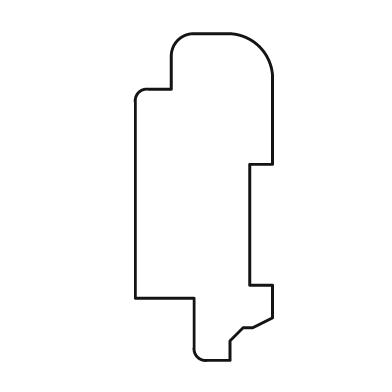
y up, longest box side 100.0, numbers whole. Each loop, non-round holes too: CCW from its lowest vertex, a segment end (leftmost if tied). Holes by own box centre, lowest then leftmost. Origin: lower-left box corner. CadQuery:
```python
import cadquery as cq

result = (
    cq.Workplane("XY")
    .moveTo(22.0, 0.0)
    .lineTo(29.0, 0.0)
    .lineTo(29.0, 6.0)
    .lineTo(33.0, 10.0)
    .lineTo(36.0, 10.0)
    .lineTo(42.0, 13.0)
    .lineTo(42.0, 23.0)
    .lineTo(35.0, 23.0)
    .lineTo(35.0, 60.0)
    .lineTo(42.0, 60.0)
    .lineTo(42.0, 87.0)
    .threePointArc((38.0, 96.0), (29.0, 100.0))
    .lineTo(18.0, 100.0)
    .threePointArc((13.0, 98.0), (11.0, 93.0))
    .lineTo(11.0, 83.0)
    .lineTo(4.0, 83.0)
    .threePointArc((1.0, 82.0), (0.0, 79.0))
    .lineTo(0.0, 19.0)
    .lineTo(18.0, 19.0)
    .lineTo(18.0, 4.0)
    .threePointArc((19.0, 1.0), (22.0, 0.0))
    .close()
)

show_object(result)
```